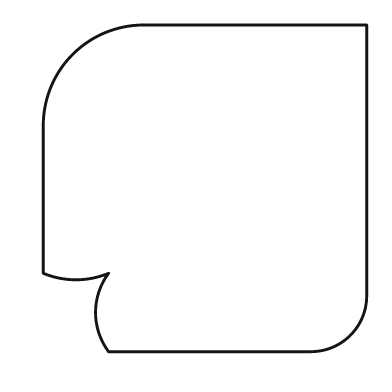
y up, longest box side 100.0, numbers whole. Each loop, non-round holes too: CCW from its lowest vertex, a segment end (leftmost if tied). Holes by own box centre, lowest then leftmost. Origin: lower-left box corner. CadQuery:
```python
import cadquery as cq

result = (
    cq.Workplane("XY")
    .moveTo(20.0, 0.0)
    .lineTo(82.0, 0.0)
    .threePointArc((94.0, 5.0), (99.0, 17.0))
    .lineTo(99.0, 100.0)
    .lineTo(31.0, 100.0)
    .threePointArc((9.0, 91.0), (0.0, 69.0))
    .lineTo(0.0, 24.0)
    .threePointArc((10.0, 22.0), (20.0, 24.0))
    .threePointArc((16.0, 12.0), (20.0, 0.0))
    .close()
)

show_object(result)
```